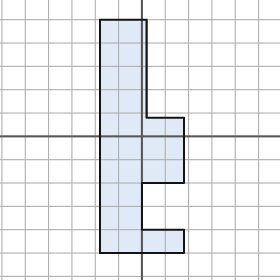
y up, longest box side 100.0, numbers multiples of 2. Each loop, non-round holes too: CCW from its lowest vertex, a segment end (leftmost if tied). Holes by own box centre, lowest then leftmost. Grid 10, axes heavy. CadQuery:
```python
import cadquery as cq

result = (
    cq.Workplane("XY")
    .moveTo(-18.0, -50.0)
    .lineTo(18.0, -50.0)
    .lineTo(18.0, -40.0)
    .lineTo(0.0, -40.0)
    .lineTo(0.0, -20.0)
    .lineTo(18.0, -20.0)
    .lineTo(18.0, 8.0)
    .lineTo(2.0, 8.0)
    .lineTo(2.0, 50.0)
    .lineTo(-18.0, 50.0)
    .close()
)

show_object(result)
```